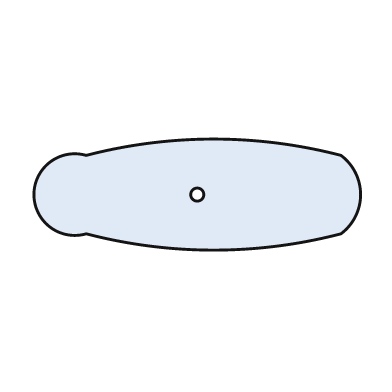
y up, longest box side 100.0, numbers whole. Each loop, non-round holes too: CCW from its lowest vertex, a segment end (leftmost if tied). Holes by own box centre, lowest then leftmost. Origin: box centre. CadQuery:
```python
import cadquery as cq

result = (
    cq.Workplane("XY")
    .moveTo(-34.0, -12.0)
    .threePointArc((5.0, -17.0), (44.0, -12.0))
    .threePointArc((50.0, 0.0), (44.0, 12.0))
    .threePointArc((5.0, 17.0), (-34.0, 12.0))
    .threePointArc((-50.0, 0.0), (-34.0, -12.0))
    .close()
    .moveTo(0.0, 0.0)
    .circle(2.0)
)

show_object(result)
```